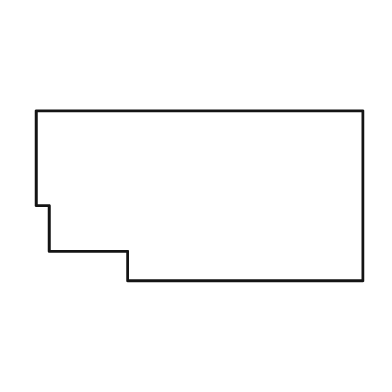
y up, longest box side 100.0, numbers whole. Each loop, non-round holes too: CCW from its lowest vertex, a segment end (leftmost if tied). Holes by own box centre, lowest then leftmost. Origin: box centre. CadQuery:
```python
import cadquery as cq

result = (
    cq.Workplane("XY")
    .moveTo(-22.0, -26.0)
    .lineTo(50.0, -26.0)
    .lineTo(50.0, 26.0)
    .lineTo(-50.0, 26.0)
    .lineTo(-50.0, -3.0)
    .lineTo(-46.0, -3.0)
    .lineTo(-46.0, -17.0)
    .lineTo(-22.0, -17.0)
    .close()
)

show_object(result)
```